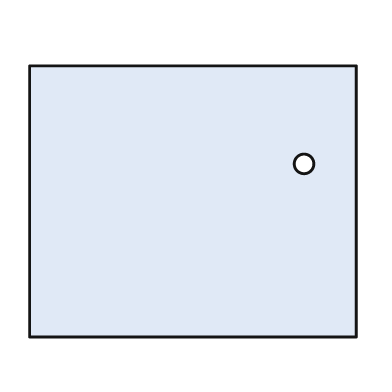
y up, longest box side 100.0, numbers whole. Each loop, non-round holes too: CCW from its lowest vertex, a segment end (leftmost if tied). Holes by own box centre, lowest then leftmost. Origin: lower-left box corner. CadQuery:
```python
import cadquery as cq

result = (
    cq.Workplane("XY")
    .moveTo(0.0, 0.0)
    .lineTo(100.0, 0.0)
    .lineTo(100.0, 83.0)
    .lineTo(0.0, 83.0)
    .close()
    .moveTo(84.0, 53.0)
    .circle(3.0)
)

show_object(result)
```